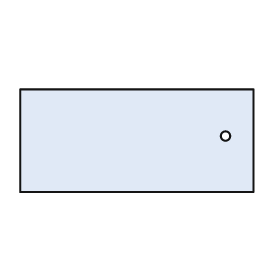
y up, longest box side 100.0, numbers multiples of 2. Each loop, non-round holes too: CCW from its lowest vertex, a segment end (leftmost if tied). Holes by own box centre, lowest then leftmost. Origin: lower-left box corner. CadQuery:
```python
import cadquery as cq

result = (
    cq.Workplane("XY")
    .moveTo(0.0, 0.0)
    .lineTo(100.0, 0.0)
    .lineTo(100.0, 44.0)
    .lineTo(0.0, 44.0)
    .close()
    .moveTo(88.0, 24.0)
    .circle(2.0)
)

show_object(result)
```